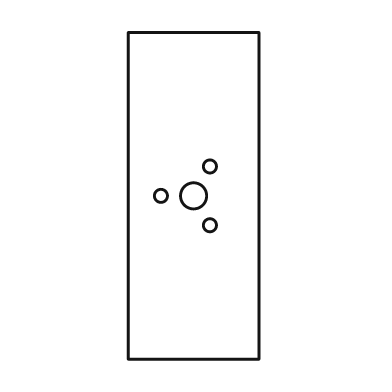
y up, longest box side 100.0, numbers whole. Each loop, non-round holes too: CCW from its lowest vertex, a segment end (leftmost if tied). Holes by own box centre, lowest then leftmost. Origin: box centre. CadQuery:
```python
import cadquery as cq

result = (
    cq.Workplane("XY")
    .moveTo(-20.0, -50.0)
    .lineTo(20.0, -50.0)
    .lineTo(20.0, 50.0)
    .lineTo(-20.0, 50.0)
    .close()
    .moveTo(5.0, -9.0)
    .circle(2.0)
    .moveTo(-10.0, 0.0)
    .circle(2.0)
    .moveTo(0.0, 0.0)
    .circle(4.0)
    .moveTo(5.0, 9.0)
    .circle(2.0)
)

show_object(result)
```